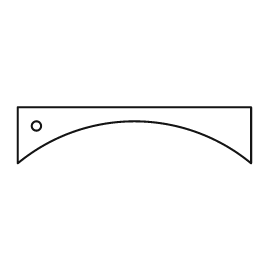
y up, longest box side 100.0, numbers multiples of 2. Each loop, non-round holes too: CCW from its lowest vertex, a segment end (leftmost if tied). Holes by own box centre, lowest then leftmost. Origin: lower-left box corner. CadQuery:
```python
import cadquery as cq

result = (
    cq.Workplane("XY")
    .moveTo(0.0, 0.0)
    .threePointArc((50.0, 18.0), (100.0, 0.0))
    .lineTo(100.0, 24.0)
    .lineTo(0.0, 24.0)
    .close()
    .moveTo(8.0, 16.0)
    .circle(2.0)
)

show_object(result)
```